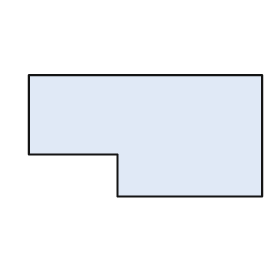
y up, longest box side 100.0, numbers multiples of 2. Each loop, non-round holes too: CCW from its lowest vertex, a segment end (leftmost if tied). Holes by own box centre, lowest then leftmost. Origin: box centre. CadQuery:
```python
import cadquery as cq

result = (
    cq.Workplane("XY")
    .moveTo(-12.0, -26.0)
    .lineTo(50.0, -26.0)
    .lineTo(50.0, 26.0)
    .lineTo(-50.0, 26.0)
    .lineTo(-50.0, -8.0)
    .lineTo(-12.0, -8.0)
    .close()
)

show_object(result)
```